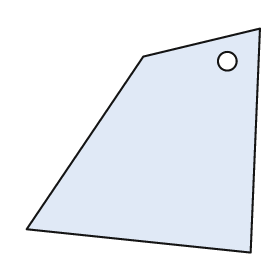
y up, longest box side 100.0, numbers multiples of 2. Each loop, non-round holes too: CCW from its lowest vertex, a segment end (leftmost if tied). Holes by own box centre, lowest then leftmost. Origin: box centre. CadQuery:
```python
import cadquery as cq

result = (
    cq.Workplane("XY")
    .moveTo(46.0, -48.0)
    .lineTo(50.0, 48.0)
    .lineTo(0.0, 36.0)
    .lineTo(-50.0, -38.0)
    .close()
    .moveTo(36.0, 34.0)
    .circle(4.0)
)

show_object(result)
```